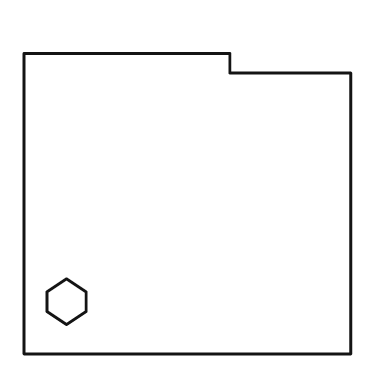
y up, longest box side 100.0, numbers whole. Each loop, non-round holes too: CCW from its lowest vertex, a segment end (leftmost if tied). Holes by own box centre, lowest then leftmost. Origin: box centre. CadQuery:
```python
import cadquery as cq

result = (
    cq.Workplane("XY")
    .moveTo(-50.0, -46.0)
    .lineTo(50.0, -46.0)
    .lineTo(50.0, 40.0)
    .lineTo(13.0, 40.0)
    .lineTo(13.0, 46.0)
    .lineTo(-50.0, 46.0)
    .close()
    .moveTo(-37.0, -37.0)
    .lineTo(-31.0, -33.0)
    .lineTo(-31.0, -27.0)
    .lineTo(-37.0, -23.0)
    .lineTo(-43.0, -27.0)
    .lineTo(-43.0, -33.0)
    .close()
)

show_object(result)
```